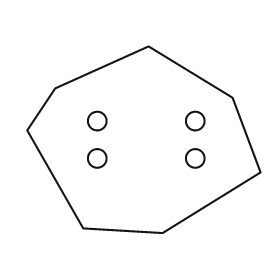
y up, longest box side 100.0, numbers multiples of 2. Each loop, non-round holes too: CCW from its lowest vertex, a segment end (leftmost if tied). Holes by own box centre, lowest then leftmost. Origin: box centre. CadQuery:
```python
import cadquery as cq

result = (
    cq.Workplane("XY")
    .moveTo(8.0, -40.0)
    .lineTo(50.0, -14.0)
    .lineTo(38.0, 18.0)
    .lineTo(2.0, 40.0)
    .lineTo(-38.0, 22.0)
    .lineTo(-50.0, 4.0)
    .lineTo(-26.0, -38.0)
    .close()
    .moveTo(-20.0, -8.0)
    .circle(4.0)
    .moveTo(22.0, -8.0)
    .circle(4.0)
    .moveTo(-20.0, 8.0)
    .circle(4.0)
    .moveTo(22.0, 8.0)
    .circle(4.0)
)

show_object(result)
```